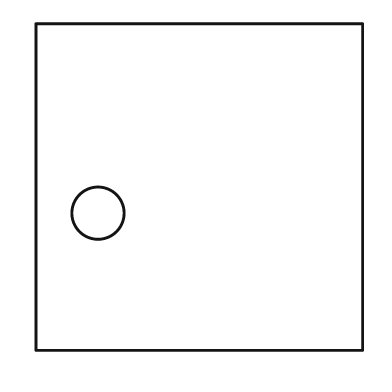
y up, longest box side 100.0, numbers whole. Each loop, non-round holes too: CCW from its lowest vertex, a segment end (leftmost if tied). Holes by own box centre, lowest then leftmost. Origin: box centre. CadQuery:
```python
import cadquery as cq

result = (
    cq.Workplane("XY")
    .moveTo(-50.0, -50.0)
    .lineTo(50.0, -50.0)
    .lineTo(50.0, 50.0)
    .lineTo(-50.0, 50.0)
    .close()
    .moveTo(-31.0, -8.0)
    .circle(8.0)
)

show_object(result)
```